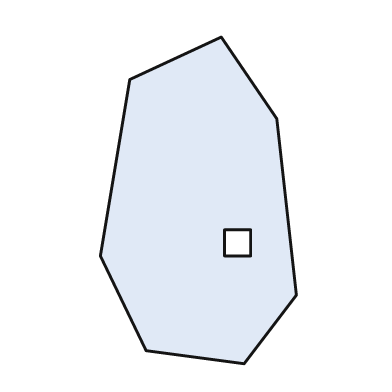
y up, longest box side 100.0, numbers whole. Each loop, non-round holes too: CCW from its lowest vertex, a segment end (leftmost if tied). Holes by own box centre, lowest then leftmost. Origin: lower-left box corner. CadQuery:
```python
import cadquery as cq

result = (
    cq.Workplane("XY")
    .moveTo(44.0, 0.0)
    .lineTo(60.0, 21.0)
    .lineTo(54.0, 75.0)
    .lineTo(37.0, 100.0)
    .lineTo(9.0, 87.0)
    .lineTo(0.0, 33.0)
    .lineTo(14.0, 4.0)
    .close()
    .moveTo(38.0, 33.0)
    .lineTo(46.0, 33.0)
    .lineTo(46.0, 41.0)
    .lineTo(38.0, 41.0)
    .close()
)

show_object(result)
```